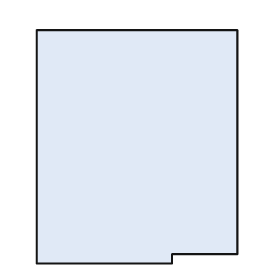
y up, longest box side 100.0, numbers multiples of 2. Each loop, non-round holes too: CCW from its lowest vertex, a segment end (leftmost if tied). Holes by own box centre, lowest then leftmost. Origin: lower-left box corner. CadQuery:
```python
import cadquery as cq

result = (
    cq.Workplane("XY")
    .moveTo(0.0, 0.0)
    .lineTo(58.0, 0.0)
    .lineTo(58.0, 4.0)
    .lineTo(86.0, 4.0)
    .lineTo(86.0, 100.0)
    .lineTo(0.0, 100.0)
    .close()
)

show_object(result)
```